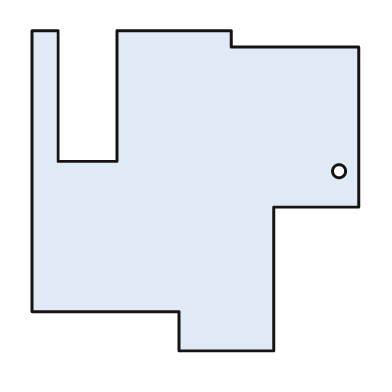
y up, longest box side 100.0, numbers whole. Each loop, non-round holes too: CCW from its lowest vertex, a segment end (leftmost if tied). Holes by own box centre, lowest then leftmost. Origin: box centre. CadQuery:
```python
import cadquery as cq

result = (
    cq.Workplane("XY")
    .moveTo(-5.0, -49.0)
    .lineTo(24.0, -49.0)
    .lineTo(24.0, -5.0)
    .lineTo(50.0, -5.0)
    .lineTo(50.0, 44.0)
    .lineTo(11.0, 44.0)
    .lineTo(11.0, 49.0)
    .lineTo(-24.0, 49.0)
    .lineTo(-24.0, 9.0)
    .lineTo(-42.0, 9.0)
    .lineTo(-42.0, 49.0)
    .lineTo(-50.0, 49.0)
    .lineTo(-50.0, -37.0)
    .lineTo(-5.0, -37.0)
    .close()
    .moveTo(44.0, 6.0)
    .circle(2.0)
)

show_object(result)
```